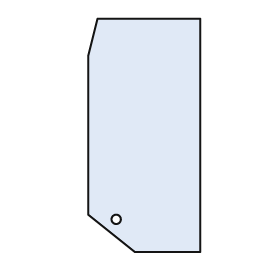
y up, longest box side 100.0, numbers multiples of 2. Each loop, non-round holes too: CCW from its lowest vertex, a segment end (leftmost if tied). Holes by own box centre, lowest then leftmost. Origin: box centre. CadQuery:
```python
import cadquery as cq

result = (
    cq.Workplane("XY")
    .moveTo(-4.0, -50.0)
    .lineTo(24.0, -50.0)
    .lineTo(24.0, 50.0)
    .lineTo(-20.0, 50.0)
    .lineTo(-24.0, 34.0)
    .lineTo(-24.0, -34.0)
    .close()
    .moveTo(-12.0, -36.0)
    .circle(2.0)
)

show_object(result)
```